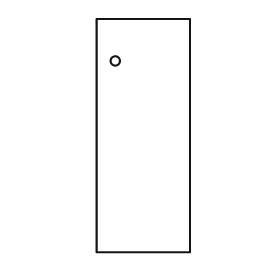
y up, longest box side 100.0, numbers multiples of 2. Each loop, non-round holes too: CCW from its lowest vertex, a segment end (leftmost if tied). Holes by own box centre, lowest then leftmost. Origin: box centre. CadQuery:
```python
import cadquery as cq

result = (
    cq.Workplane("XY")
    .moveTo(-20.0, -50.0)
    .lineTo(20.0, -50.0)
    .lineTo(20.0, 50.0)
    .lineTo(-20.0, 50.0)
    .close()
    .moveTo(-12.0, 32.0)
    .circle(2.0)
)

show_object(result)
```